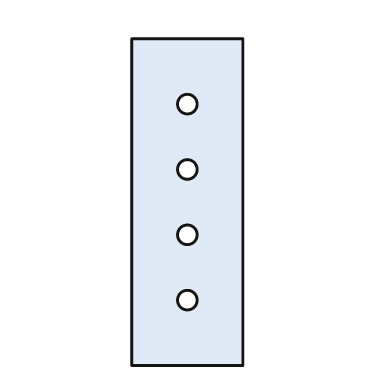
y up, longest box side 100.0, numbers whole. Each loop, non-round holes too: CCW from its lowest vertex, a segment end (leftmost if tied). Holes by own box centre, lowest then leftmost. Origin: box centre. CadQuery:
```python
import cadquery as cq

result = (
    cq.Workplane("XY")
    .moveTo(-17.0, -50.0)
    .lineTo(17.0, -50.0)
    .lineTo(17.0, 50.0)
    .lineTo(-17.0, 50.0)
    .close()
    .moveTo(0.0, -30.0)
    .circle(3.0)
    .moveTo(0.0, -10.0)
    .circle(3.0)
    .moveTo(0.0, 10.0)
    .circle(3.0)
    .moveTo(0.0, 30.0)
    .circle(3.0)
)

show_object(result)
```